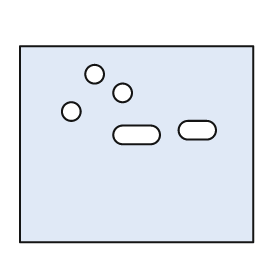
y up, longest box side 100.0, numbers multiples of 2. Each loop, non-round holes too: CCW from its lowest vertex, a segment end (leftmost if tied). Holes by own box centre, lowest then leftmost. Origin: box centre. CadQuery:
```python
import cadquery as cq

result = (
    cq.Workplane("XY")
    .moveTo(-50.0, -42.0)
    .lineTo(50.0, -42.0)
    .lineTo(50.0, 42.0)
    .lineTo(-50.0, 42.0)
    .close()
    .moveTo(-6.0, 0.0)
    .lineTo(6.0, 0.0)
    .threePointArc((10.0, 4.0), (6.0, 8.0))
    .lineTo(-6.0, 8.0)
    .threePointArc((-10.0, 4.0), (-6.0, 0.0))
    .close()
    .moveTo(22.0, 2.0)
    .lineTo(30.0, 2.0)
    .threePointArc((34.0, 6.0), (30.0, 10.0))
    .lineTo(22.0, 10.0)
    .threePointArc((18.0, 6.0), (22.0, 2.0))
    .close()
    .moveTo(-28.0, 14.0)
    .circle(4.0)
    .moveTo(-6.0, 22.0)
    .circle(4.0)
    .moveTo(-18.0, 30.0)
    .circle(4.0)
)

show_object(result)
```